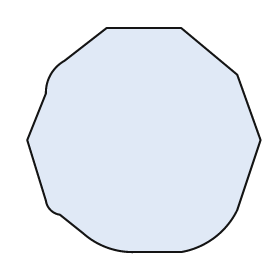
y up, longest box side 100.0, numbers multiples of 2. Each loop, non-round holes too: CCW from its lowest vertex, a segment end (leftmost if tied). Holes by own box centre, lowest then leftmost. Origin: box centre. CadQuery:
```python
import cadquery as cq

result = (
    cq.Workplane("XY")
    .moveTo(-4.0, -48.0)
    .lineTo(16.0, -48.0)
    .threePointArc((30.0, -42.0), (40.0, -30.0))
    .lineTo(50.0, 0.0)
    .lineTo(40.0, 28.0)
    .lineTo(16.0, 48.0)
    .lineTo(-16.0, 48.0)
    .lineTo(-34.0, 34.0)
    .threePointArc((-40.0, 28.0), (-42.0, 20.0))
    .lineTo(-50.0, 0.0)
    .lineTo(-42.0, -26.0)
    .threePointArc((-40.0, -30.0), (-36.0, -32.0))
    .lineTo(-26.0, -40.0)
    .threePointArc((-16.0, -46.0), (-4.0, -48.0))
    .close()
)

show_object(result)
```